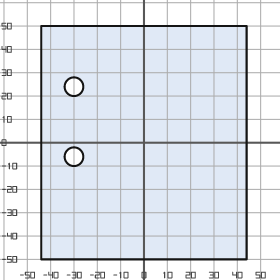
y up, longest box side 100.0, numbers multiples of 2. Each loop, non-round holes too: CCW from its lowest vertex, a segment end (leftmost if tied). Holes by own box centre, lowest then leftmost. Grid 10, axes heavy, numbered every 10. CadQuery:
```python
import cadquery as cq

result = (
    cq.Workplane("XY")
    .moveTo(-44.0, -50.0)
    .lineTo(44.0, -50.0)
    .lineTo(44.0, 50.0)
    .lineTo(-44.0, 50.0)
    .close()
    .moveTo(-30.0, -6.0)
    .circle(4.0)
    .moveTo(-30.0, 24.0)
    .circle(4.0)
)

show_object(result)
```